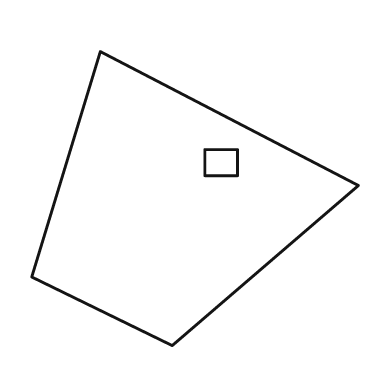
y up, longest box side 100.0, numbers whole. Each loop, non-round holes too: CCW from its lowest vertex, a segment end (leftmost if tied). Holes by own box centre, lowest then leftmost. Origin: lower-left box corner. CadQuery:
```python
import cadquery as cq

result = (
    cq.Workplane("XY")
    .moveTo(43.0, 0.0)
    .lineTo(100.0, 49.0)
    .lineTo(21.0, 90.0)
    .lineTo(0.0, 21.0)
    .close()
    .moveTo(53.0, 52.0)
    .lineTo(63.0, 52.0)
    .lineTo(63.0, 60.0)
    .lineTo(53.0, 60.0)
    .close()
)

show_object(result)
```